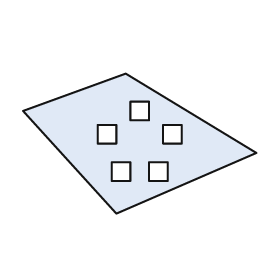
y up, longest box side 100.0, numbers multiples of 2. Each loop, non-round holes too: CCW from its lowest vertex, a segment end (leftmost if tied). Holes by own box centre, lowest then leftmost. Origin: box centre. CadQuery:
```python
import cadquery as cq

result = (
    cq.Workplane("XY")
    .moveTo(-10.0, -30.0)
    .lineTo(50.0, -4.0)
    .lineTo(-6.0, 30.0)
    .lineTo(-50.0, 14.0)
    .close()
    .moveTo(-12.0, -16.0)
    .lineTo(-4.0, -16.0)
    .lineTo(-4.0, -8.0)
    .lineTo(-12.0, -8.0)
    .close()
    .moveTo(4.0, -16.0)
    .lineTo(12.0, -16.0)
    .lineTo(12.0, -8.0)
    .lineTo(4.0, -8.0)
    .close()
    .moveTo(-18.0, 0.0)
    .lineTo(-10.0, 0.0)
    .lineTo(-10.0, 8.0)
    .lineTo(-18.0, 8.0)
    .close()
    .moveTo(10.0, 0.0)
    .lineTo(18.0, 0.0)
    .lineTo(18.0, 8.0)
    .lineTo(10.0, 8.0)
    .close()
    .moveTo(-4.0, 10.0)
    .lineTo(4.0, 10.0)
    .lineTo(4.0, 18.0)
    .lineTo(-4.0, 18.0)
    .close()
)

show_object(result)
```